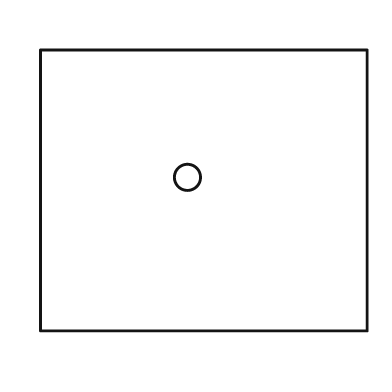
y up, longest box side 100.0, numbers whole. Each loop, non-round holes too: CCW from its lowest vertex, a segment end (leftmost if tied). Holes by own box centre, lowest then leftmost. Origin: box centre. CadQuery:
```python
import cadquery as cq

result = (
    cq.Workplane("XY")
    .moveTo(-50.0, -43.0)
    .lineTo(50.0, -43.0)
    .lineTo(50.0, 43.0)
    .lineTo(-50.0, 43.0)
    .close()
    .moveTo(-5.0, 4.0)
    .circle(4.0)
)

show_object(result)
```